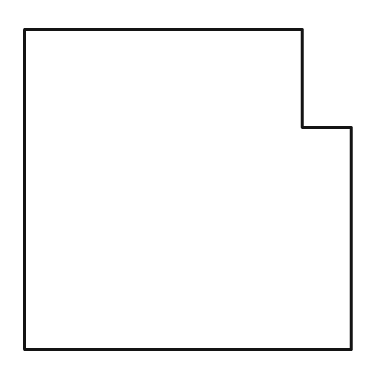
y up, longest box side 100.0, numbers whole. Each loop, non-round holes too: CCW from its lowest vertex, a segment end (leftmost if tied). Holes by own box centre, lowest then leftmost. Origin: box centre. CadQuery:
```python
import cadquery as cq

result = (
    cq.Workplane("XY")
    .moveTo(-50.0, -49.0)
    .lineTo(50.0, -49.0)
    .lineTo(50.0, 19.0)
    .lineTo(35.0, 19.0)
    .lineTo(35.0, 49.0)
    .lineTo(-50.0, 49.0)
    .close()
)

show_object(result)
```